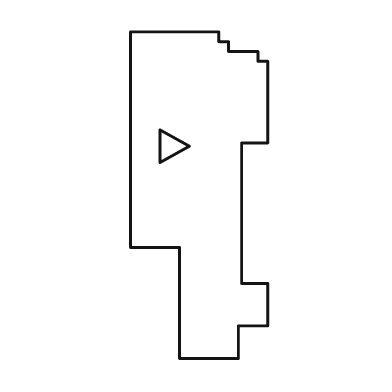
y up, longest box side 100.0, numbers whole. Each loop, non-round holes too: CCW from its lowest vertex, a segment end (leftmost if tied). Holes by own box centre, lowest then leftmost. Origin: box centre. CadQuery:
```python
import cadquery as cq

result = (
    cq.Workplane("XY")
    .moveTo(-6.0, -50.0)
    .lineTo(12.0, -50.0)
    .lineTo(12.0, -40.0)
    .lineTo(21.0, -40.0)
    .lineTo(21.0, -27.0)
    .lineTo(13.0, -27.0)
    .lineTo(13.0, 16.0)
    .lineTo(21.0, 16.0)
    .lineTo(21.0, 41.0)
    .lineTo(18.0, 41.0)
    .lineTo(18.0, 44.0)
    .lineTo(9.0, 44.0)
    .lineTo(9.0, 47.0)
    .lineTo(6.0, 47.0)
    .lineTo(6.0, 50.0)
    .lineTo(-21.0, 50.0)
    .lineTo(-21.0, -16.0)
    .lineTo(-6.0, -16.0)
    .close()
    .moveTo(-12.0, 10.0)
    .lineTo(-3.0, 15.0)
    .lineTo(-12.0, 20.0)
    .close()
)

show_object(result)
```